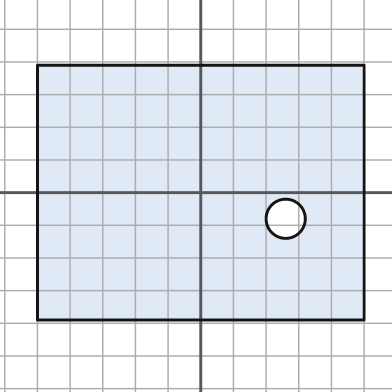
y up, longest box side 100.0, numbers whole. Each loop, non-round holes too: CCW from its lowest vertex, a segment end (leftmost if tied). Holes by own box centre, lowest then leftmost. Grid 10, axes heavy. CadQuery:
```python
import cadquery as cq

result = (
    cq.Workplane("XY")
    .moveTo(-50.0, -39.0)
    .lineTo(50.0, -39.0)
    .lineTo(50.0, 39.0)
    .lineTo(-50.0, 39.0)
    .close()
    .moveTo(26.0, -8.0)
    .circle(6.0)
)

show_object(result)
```